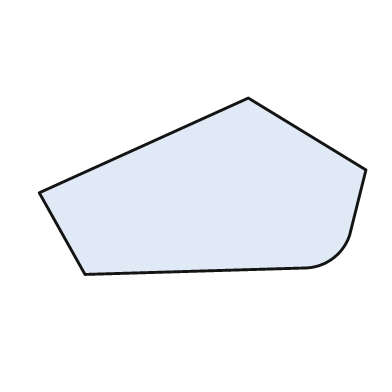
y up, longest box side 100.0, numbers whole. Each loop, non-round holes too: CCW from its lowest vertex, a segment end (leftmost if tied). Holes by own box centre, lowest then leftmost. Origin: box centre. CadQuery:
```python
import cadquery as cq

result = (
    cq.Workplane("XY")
    .moveTo(-36.0, -27.0)
    .lineTo(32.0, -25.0)
    .threePointArc((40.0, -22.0), (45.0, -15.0))
    .lineTo(50.0, 5.0)
    .lineTo(14.0, 27.0)
    .lineTo(-50.0, -2.0)
    .close()
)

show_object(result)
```